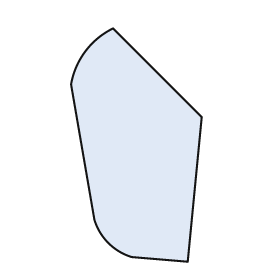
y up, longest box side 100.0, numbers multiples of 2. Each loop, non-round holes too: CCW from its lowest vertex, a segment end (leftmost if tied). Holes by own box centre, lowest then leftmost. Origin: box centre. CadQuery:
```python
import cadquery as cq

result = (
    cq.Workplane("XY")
    .moveTo(22.0, -50.0)
    .lineTo(28.0, 12.0)
    .lineTo(-10.0, 50.0)
    .threePointArc((-22.0, 40.0), (-28.0, 26.0))
    .lineTo(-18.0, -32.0)
    .threePointArc((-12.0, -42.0), (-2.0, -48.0))
    .close()
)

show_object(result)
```